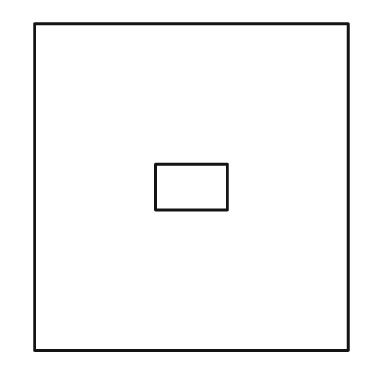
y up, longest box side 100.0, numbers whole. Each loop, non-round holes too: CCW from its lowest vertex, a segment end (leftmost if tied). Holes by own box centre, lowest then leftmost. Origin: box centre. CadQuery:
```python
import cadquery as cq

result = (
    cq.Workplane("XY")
    .moveTo(-48.0, -50.0)
    .lineTo(48.0, -50.0)
    .lineTo(48.0, 50.0)
    .lineTo(-48.0, 50.0)
    .close()
    .moveTo(-11.0, -7.0)
    .lineTo(11.0, -7.0)
    .lineTo(11.0, 7.0)
    .lineTo(-11.0, 7.0)
    .close()
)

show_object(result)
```